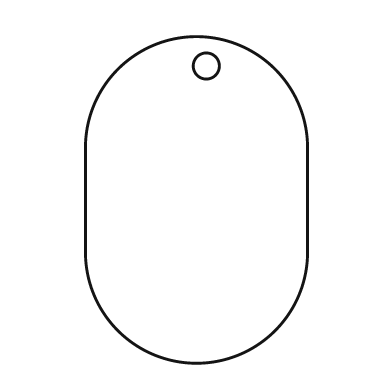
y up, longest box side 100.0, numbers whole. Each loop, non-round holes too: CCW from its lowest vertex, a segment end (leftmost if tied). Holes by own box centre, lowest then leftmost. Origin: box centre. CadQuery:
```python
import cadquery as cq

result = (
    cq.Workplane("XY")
    .moveTo(-34.0, -16.0)
    .threePointArc((0.0, -50.0), (34.0, -16.0))
    .lineTo(34.0, 16.0)
    .threePointArc((0.0, 50.0), (-34.0, 16.0))
    .close()
    .moveTo(3.0, 41.0)
    .circle(4.0)
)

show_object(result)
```